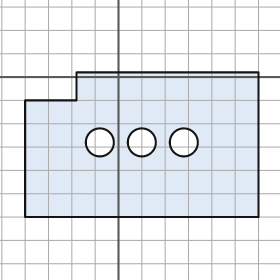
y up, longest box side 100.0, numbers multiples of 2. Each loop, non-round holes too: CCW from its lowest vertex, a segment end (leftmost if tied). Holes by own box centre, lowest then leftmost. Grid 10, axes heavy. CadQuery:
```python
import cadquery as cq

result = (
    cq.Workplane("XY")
    .moveTo(-40.0, -60.0)
    .lineTo(60.0, -60.0)
    .lineTo(60.0, 2.0)
    .lineTo(-18.0, 2.0)
    .lineTo(-18.0, -10.0)
    .lineTo(-40.0, -10.0)
    .close()
    .moveTo(-8.0, -28.0)
    .circle(6.0)
    .moveTo(10.0, -28.0)
    .circle(6.0)
    .moveTo(28.0, -28.0)
    .circle(6.0)
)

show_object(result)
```